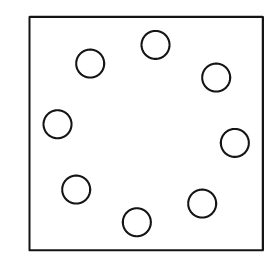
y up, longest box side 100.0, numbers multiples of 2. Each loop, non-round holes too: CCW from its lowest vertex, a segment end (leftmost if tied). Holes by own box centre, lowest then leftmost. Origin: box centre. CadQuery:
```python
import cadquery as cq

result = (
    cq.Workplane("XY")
    .moveTo(-50.0, -50.0)
    .lineTo(50.0, -50.0)
    .lineTo(50.0, 50.0)
    .lineTo(-50.0, 50.0)
    .close()
    .moveTo(-4.0, -38.0)
    .circle(6.0)
    .moveTo(24.0, -30.0)
    .circle(6.0)
    .moveTo(-30.0, -24.0)
    .circle(6.0)
    .moveTo(38.0, -4.0)
    .circle(6.0)
    .moveTo(-38.0, 4.0)
    .circle(6.0)
    .moveTo(30.0, 24.0)
    .circle(6.0)
    .moveTo(-24.0, 30.0)
    .circle(6.0)
    .moveTo(4.0, 38.0)
    .circle(6.0)
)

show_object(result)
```